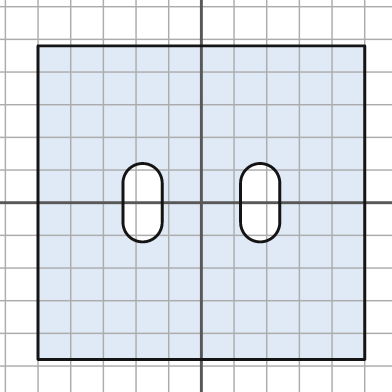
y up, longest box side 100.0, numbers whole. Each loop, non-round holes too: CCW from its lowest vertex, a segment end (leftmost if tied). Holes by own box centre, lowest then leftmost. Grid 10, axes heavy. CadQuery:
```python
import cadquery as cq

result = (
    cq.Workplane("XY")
    .moveTo(-50.0, -48.0)
    .lineTo(50.0, -48.0)
    .lineTo(50.0, 48.0)
    .lineTo(-50.0, 48.0)
    .close()
    .moveTo(-24.0, -6.0)
    .threePointArc((-18.0, -12.0), (-12.0, -6.0))
    .lineTo(-12.0, 6.0)
    .threePointArc((-18.0, 12.0), (-24.0, 6.0))
    .close()
    .moveTo(12.0, -6.0)
    .threePointArc((18.0, -12.0), (24.0, -6.0))
    .lineTo(24.0, 6.0)
    .threePointArc((18.0, 12.0), (12.0, 6.0))
    .close()
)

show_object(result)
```